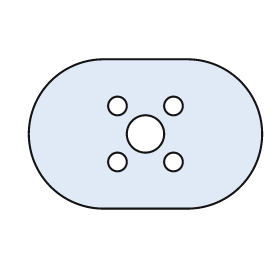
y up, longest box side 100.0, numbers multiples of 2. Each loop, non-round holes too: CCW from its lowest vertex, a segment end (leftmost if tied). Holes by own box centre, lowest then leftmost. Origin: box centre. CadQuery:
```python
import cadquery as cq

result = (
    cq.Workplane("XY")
    .moveTo(-18.0, -32.0)
    .lineTo(18.0, -32.0)
    .threePointArc((50.0, 0.0), (18.0, 32.0))
    .lineTo(-18.0, 32.0)
    .threePointArc((-50.0, 0.0), (-18.0, -32.0))
    .close()
    .moveTo(-12.0, -12.0)
    .circle(4.0)
    .moveTo(12.0, -12.0)
    .circle(4.0)
    .moveTo(0.0, 0.0)
    .circle(8.0)
    .moveTo(-12.0, 12.0)
    .circle(4.0)
    .moveTo(12.0, 12.0)
    .circle(4.0)
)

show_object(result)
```